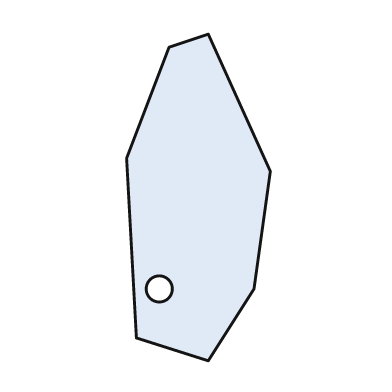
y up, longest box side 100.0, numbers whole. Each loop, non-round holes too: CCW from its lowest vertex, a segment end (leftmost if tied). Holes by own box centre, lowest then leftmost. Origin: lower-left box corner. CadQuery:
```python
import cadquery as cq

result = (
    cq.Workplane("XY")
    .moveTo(25.0, 0.0)
    .lineTo(39.0, 22.0)
    .lineTo(44.0, 58.0)
    .lineTo(25.0, 100.0)
    .lineTo(13.0, 96.0)
    .lineTo(0.0, 62.0)
    .lineTo(3.0, 7.0)
    .close()
    .moveTo(10.0, 22.0)
    .circle(4.0)
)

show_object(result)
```